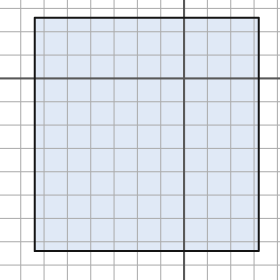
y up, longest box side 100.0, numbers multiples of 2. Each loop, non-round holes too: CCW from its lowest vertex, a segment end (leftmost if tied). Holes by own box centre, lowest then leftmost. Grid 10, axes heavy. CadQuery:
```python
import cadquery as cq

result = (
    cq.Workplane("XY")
    .moveTo(-64.0, -74.0)
    .lineTo(32.0, -74.0)
    .lineTo(32.0, 26.0)
    .lineTo(-64.0, 26.0)
    .close()
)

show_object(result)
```